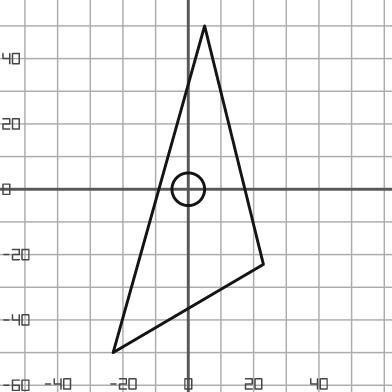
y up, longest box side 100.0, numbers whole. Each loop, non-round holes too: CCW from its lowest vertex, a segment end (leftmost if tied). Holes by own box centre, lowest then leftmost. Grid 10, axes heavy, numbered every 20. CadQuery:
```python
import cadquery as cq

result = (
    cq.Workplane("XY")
    .moveTo(-23.0, -50.0)
    .lineTo(23.0, -23.0)
    .lineTo(5.0, 50.0)
    .close()
    .moveTo(0.0, 0.0)
    .circle(5.0)
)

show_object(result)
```